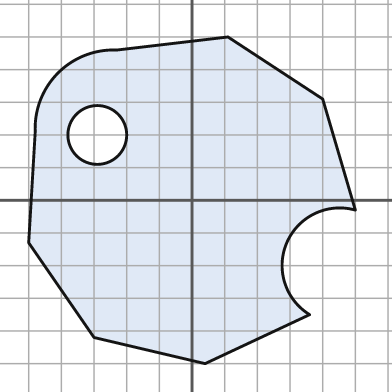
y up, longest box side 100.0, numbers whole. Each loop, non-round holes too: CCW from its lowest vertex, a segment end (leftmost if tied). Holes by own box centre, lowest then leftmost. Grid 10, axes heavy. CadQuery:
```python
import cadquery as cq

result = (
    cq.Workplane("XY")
    .moveTo(4.0, -50.0)
    .lineTo(36.0, -35.0)
    .threePointArc((29.0, -13.0), (50.0, -3.0))
    .lineTo(40.0, 31.0)
    .lineTo(11.0, 50.0)
    .lineTo(-23.0, 46.0)
    .threePointArc((-41.0, 39.0), (-48.0, 21.0))
    .lineTo(-50.0, -13.0)
    .lineTo(-30.0, -42.0)
    .close()
    .moveTo(-29.0, 20.0)
    .circle(9.0)
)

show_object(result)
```